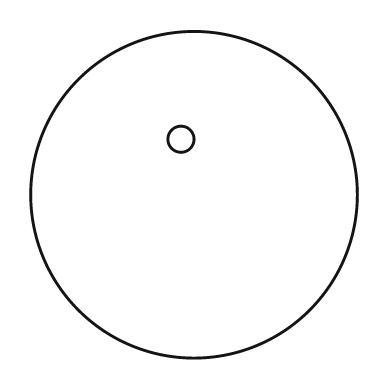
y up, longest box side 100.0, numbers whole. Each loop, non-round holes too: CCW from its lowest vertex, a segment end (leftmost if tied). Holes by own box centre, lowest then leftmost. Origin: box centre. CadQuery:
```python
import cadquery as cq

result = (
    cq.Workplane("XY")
    .moveTo(0.0, 0.0)
    .circle(50.0)
    .moveTo(-4.0, 17.0)
    .circle(4.0)
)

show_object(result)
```